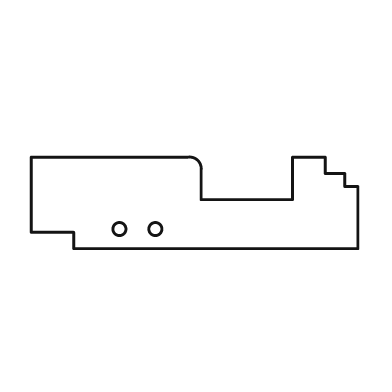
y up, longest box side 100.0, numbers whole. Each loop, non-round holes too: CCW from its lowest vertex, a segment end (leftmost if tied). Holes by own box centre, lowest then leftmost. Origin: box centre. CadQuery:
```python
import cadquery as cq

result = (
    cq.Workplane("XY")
    .moveTo(-37.0, -14.0)
    .lineTo(50.0, -14.0)
    .lineTo(50.0, 5.0)
    .lineTo(46.0, 5.0)
    .lineTo(46.0, 9.0)
    .lineTo(40.0, 9.0)
    .lineTo(40.0, 14.0)
    .lineTo(30.0, 14.0)
    .lineTo(30.0, 1.0)
    .lineTo(2.0, 1.0)
    .lineTo(2.0, 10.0)
    .threePointArc((1.0, 13.0), (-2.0, 14.0))
    .lineTo(-50.0, 14.0)
    .lineTo(-50.0, -9.0)
    .lineTo(-37.0, -9.0)
    .close()
    .moveTo(-23.0, -8.0)
    .circle(2.0)
    .moveTo(-12.0, -8.0)
    .circle(2.0)
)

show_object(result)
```